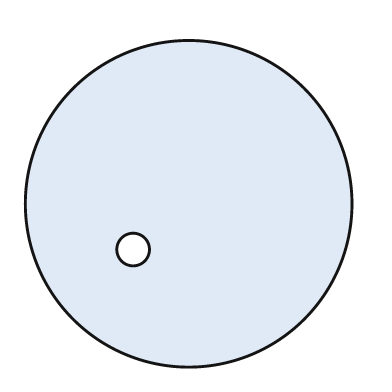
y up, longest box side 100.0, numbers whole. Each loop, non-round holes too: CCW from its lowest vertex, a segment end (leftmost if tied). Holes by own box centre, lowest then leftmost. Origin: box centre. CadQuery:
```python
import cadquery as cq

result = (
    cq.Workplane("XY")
    .moveTo(0.0, 0.0)
    .circle(50.0)
    .moveTo(-17.0, -14.0)
    .circle(5.0)
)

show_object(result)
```